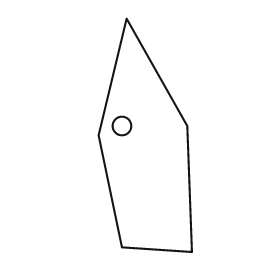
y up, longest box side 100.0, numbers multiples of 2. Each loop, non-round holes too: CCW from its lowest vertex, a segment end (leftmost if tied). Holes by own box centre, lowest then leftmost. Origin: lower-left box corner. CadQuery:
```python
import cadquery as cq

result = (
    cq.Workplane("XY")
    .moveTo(40.0, 0.0)
    .lineTo(38.0, 54.0)
    .lineTo(12.0, 100.0)
    .lineTo(0.0, 50.0)
    .lineTo(10.0, 2.0)
    .close()
    .moveTo(10.0, 54.0)
    .circle(4.0)
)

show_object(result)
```